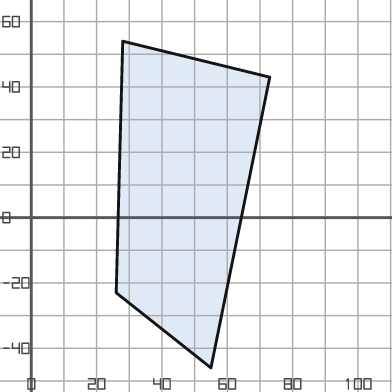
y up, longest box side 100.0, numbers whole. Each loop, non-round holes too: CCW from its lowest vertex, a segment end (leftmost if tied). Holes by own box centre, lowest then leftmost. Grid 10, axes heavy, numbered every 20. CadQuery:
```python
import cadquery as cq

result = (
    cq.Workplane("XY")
    .moveTo(55.0, -46.0)
    .lineTo(73.0, 43.0)
    .lineTo(28.0, 54.0)
    .lineTo(26.0, -23.0)
    .close()
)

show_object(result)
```